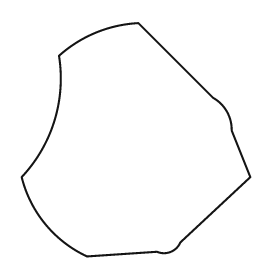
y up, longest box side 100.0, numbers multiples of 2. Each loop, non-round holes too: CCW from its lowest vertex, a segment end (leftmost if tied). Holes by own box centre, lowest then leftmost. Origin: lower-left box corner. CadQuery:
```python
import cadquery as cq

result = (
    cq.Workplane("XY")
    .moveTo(28.0, 0.0)
    .lineTo(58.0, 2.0)
    .threePointArc((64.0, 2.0), (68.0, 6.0))
    .lineTo(98.0, 34.0)
    .lineTo(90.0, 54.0)
    .threePointArc((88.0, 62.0), (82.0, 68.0))
    .lineTo(50.0, 100.0)
    .threePointArc((32.0, 96.0), (16.0, 86.0))
    .threePointArc((14.0, 58.0), (0.0, 34.0))
    .threePointArc((10.0, 14.0), (28.0, 0.0))
    .close()
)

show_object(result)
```